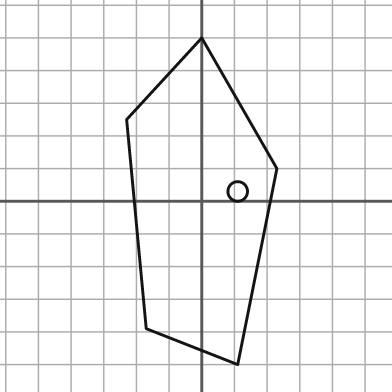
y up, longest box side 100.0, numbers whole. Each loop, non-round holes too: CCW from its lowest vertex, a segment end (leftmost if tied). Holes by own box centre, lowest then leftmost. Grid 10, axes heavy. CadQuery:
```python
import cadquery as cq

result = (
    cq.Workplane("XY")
    .moveTo(11.0, -50.0)
    .lineTo(23.0, 10.0)
    .lineTo(0.0, 50.0)
    .lineTo(-23.0, 25.0)
    .lineTo(-17.0, -39.0)
    .close()
    .moveTo(11.0, 3.0)
    .circle(3.0)
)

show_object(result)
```